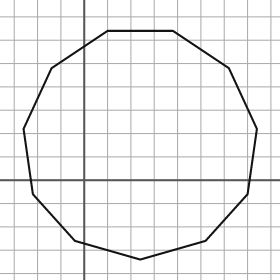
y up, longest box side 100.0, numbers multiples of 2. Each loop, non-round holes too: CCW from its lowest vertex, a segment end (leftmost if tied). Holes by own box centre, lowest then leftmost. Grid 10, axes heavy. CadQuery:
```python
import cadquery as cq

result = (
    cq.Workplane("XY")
    .moveTo(24.0, -34.0)
    .lineTo(52.0, -26.0)
    .lineTo(70.0, -6.0)
    .lineTo(74.0, 22.0)
    .lineTo(62.0, 48.0)
    .lineTo(38.0, 64.0)
    .lineTo(10.0, 64.0)
    .lineTo(-14.0, 48.0)
    .lineTo(-26.0, 22.0)
    .lineTo(-22.0, -6.0)
    .lineTo(-4.0, -26.0)
    .close()
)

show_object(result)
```